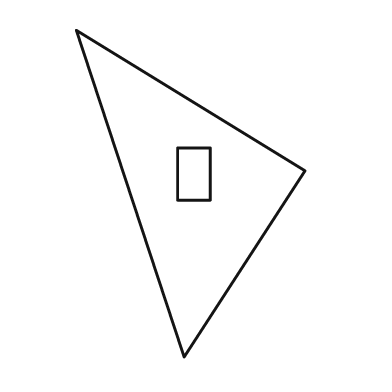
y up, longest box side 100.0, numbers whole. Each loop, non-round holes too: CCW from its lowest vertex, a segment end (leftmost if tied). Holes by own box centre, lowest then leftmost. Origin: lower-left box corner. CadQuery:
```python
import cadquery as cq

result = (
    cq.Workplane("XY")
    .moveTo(33.0, 0.0)
    .lineTo(70.0, 57.0)
    .lineTo(0.0, 100.0)
    .close()
    .moveTo(31.0, 48.0)
    .lineTo(41.0, 48.0)
    .lineTo(41.0, 64.0)
    .lineTo(31.0, 64.0)
    .close()
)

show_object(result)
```